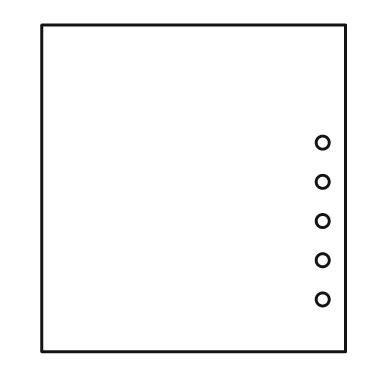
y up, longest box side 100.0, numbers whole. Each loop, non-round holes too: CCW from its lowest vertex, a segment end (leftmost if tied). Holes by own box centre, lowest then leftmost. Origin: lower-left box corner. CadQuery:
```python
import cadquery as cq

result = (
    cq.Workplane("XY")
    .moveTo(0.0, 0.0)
    .lineTo(93.0, 0.0)
    .lineTo(93.0, 100.0)
    .lineTo(0.0, 100.0)
    .close()
    .moveTo(86.0, 16.0)
    .circle(2.0)
    .moveTo(86.0, 28.0)
    .circle(2.0)
    .moveTo(86.0, 40.0)
    .circle(2.0)
    .moveTo(86.0, 52.0)
    .circle(2.0)
    .moveTo(86.0, 64.0)
    .circle(2.0)
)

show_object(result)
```